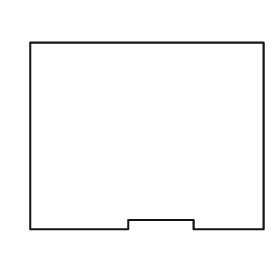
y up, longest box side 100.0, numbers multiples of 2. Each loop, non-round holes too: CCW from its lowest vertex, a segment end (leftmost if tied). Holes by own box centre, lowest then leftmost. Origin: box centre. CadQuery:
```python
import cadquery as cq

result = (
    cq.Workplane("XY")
    .moveTo(-50.0, -40.0)
    .lineTo(-8.0, -40.0)
    .lineTo(-8.0, -36.0)
    .lineTo(20.0, -36.0)
    .lineTo(20.0, -40.0)
    .lineTo(50.0, -40.0)
    .lineTo(50.0, 40.0)
    .lineTo(-50.0, 40.0)
    .close()
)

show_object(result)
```